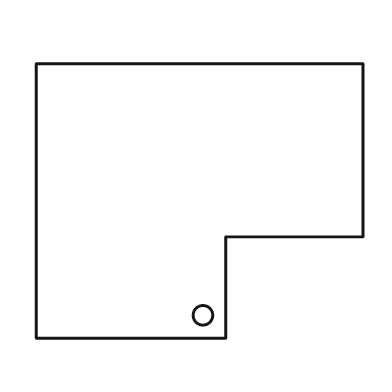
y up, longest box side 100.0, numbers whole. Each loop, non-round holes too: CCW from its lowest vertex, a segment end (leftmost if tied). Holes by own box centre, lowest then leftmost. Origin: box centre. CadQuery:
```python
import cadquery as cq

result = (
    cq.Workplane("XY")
    .moveTo(-50.0, -42.0)
    .lineTo(8.0, -42.0)
    .lineTo(8.0, -11.0)
    .lineTo(50.0, -11.0)
    .lineTo(50.0, 42.0)
    .lineTo(-50.0, 42.0)
    .close()
    .moveTo(1.0, -35.0)
    .circle(3.0)
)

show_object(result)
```